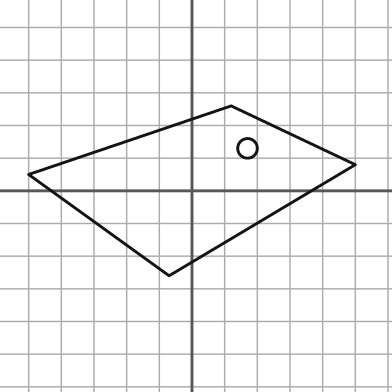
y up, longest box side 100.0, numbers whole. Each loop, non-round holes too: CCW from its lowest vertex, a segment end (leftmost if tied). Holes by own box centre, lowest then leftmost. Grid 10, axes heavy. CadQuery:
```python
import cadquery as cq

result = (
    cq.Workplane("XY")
    .moveTo(-7.0, -26.0)
    .lineTo(50.0, 8.0)
    .lineTo(12.0, 26.0)
    .lineTo(-50.0, 5.0)
    .close()
    .moveTo(17.0, 13.0)
    .circle(3.0)
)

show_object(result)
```